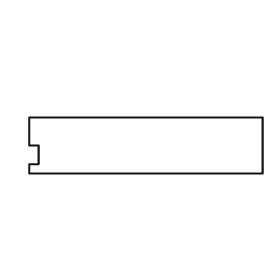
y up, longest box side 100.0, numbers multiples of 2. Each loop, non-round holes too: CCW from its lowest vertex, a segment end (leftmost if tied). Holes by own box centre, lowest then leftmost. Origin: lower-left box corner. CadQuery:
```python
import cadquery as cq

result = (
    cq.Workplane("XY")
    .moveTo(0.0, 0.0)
    .lineTo(100.0, 0.0)
    .lineTo(100.0, 24.0)
    .lineTo(0.0, 24.0)
    .lineTo(0.0, 12.0)
    .lineTo(4.0, 12.0)
    .lineTo(4.0, 4.0)
    .lineTo(0.0, 4.0)
    .close()
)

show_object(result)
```